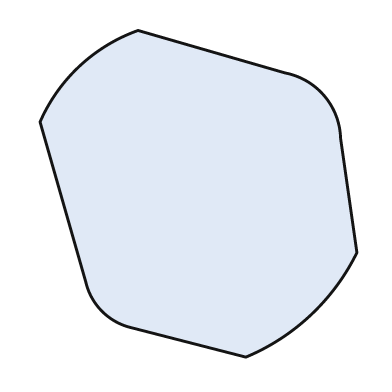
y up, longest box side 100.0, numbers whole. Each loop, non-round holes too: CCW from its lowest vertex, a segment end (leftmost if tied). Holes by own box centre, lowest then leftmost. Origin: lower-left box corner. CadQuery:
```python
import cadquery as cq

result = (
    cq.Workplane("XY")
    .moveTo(63.0, 0.0)
    .threePointArc((83.0, 13.0), (97.0, 32.0))
    .lineTo(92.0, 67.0)
    .threePointArc((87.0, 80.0), (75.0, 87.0))
    .lineTo(30.0, 100.0)
    .threePointArc((12.0, 89.0), (0.0, 72.0))
    .lineTo(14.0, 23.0)
    .threePointArc((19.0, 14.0), (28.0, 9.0))
    .close()
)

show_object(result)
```